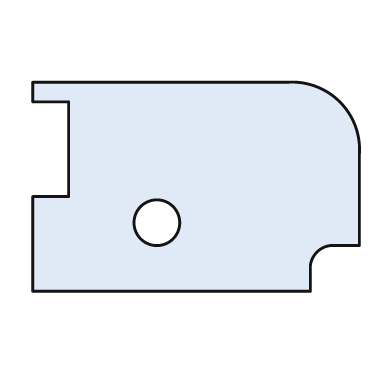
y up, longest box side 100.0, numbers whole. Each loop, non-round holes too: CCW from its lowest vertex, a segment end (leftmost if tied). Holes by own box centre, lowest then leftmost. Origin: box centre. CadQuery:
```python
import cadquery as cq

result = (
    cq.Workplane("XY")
    .moveTo(-50.0, -32.0)
    .lineTo(35.0, -32.0)
    .lineTo(35.0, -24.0)
    .threePointArc((37.0, -20.0), (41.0, -18.0))
    .lineTo(50.0, -18.0)
    .lineTo(50.0, 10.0)
    .threePointArc((44.0, 26.0), (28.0, 32.0))
    .lineTo(-50.0, 32.0)
    .lineTo(-50.0, 26.0)
    .lineTo(-39.0, 26.0)
    .lineTo(-39.0, -3.0)
    .lineTo(-50.0, -3.0)
    .close()
    .moveTo(-12.0, -11.0)
    .circle(7.0)
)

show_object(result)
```